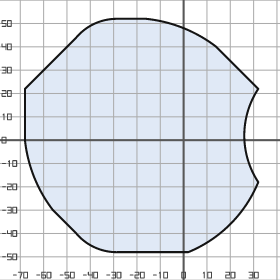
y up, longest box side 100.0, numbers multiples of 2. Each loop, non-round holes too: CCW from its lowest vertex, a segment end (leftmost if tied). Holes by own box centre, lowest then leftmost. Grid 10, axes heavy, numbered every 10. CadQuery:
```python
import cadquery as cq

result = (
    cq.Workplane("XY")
    .moveTo(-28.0, -48.0)
    .lineTo(2.0, -48.0)
    .threePointArc((20.0, -36.0), (32.0, -18.0))
    .threePointArc((26.0, 2.0), (32.0, 22.0))
    .lineTo(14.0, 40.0)
    .threePointArc((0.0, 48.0), (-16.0, 52.0))
    .lineTo(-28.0, 52.0)
    .threePointArc((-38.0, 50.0), (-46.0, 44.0))
    .lineTo(-68.0, 22.0)
    .lineTo(-68.0, 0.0)
    .threePointArc((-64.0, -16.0), (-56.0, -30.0))
    .lineTo(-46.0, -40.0)
    .threePointArc((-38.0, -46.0), (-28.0, -48.0))
    .close()
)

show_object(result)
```